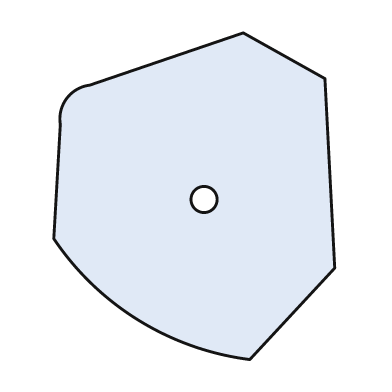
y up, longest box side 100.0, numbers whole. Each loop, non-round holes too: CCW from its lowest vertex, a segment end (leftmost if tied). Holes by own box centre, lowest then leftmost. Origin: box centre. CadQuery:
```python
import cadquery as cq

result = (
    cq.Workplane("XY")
    .moveTo(17.0, -50.0)
    .lineTo(43.0, -22.0)
    .lineTo(40.0, 36.0)
    .lineTo(15.0, 50.0)
    .lineTo(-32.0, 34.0)
    .threePointArc((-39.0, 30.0), (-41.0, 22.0))
    .lineTo(-43.0, -13.0)
    .threePointArc((-17.0, -38.0), (17.0, -50.0))
    .close()
    .moveTo(3.0, -1.0)
    .circle(4.0)
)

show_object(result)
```